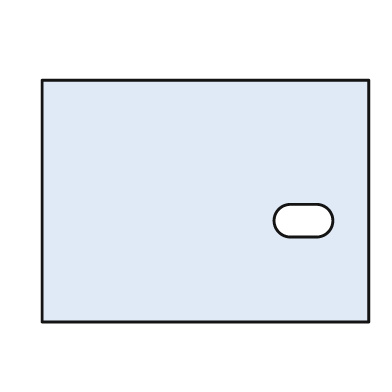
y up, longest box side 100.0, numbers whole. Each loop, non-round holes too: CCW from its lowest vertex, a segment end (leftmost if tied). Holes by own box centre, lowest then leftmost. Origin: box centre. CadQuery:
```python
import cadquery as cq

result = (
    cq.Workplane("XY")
    .moveTo(-50.0, -37.0)
    .lineTo(50.0, -37.0)
    .lineTo(50.0, 37.0)
    .lineTo(-50.0, 37.0)
    .close()
    .moveTo(26.0, -11.0)
    .lineTo(34.0, -11.0)
    .threePointArc((39.0, -6.0), (34.0, -1.0))
    .lineTo(26.0, -1.0)
    .threePointArc((21.0, -6.0), (26.0, -11.0))
    .close()
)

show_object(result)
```